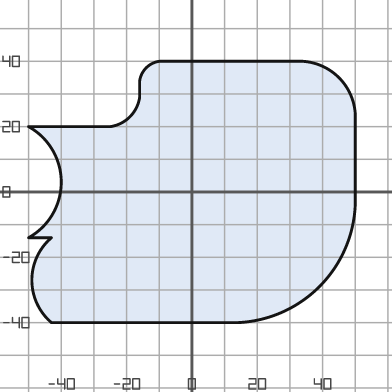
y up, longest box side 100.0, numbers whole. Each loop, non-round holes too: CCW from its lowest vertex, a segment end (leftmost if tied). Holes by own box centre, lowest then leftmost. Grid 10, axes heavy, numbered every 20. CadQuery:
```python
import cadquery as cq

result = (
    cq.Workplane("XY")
    .moveTo(-43.0, -40.0)
    .lineTo(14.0, -40.0)
    .threePointArc((39.0, -29.0), (50.0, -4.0))
    .lineTo(50.0, 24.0)
    .threePointArc((45.0, 35.0), (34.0, 40.0))
    .lineTo(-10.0, 40.0)
    .threePointArc((-14.0, 38.0), (-16.0, 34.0))
    .lineTo(-16.0, 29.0)
    .threePointArc((-19.0, 23.0), (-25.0, 20.0))
    .lineTo(-50.0, 20.0)
    .threePointArc((-40.0, 3.0), (-50.0, -14.0))
    .lineTo(-43.0, -14.0)
    .threePointArc((-49.0, -27.0), (-43.0, -40.0))
    .close()
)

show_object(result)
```